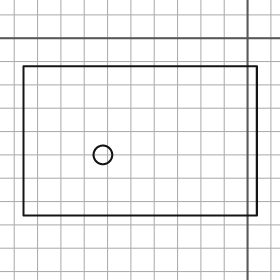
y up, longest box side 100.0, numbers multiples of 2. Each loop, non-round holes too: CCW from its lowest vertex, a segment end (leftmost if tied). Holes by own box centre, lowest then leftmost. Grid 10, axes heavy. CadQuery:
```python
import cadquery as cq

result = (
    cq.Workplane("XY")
    .moveTo(-96.0, -76.0)
    .lineTo(4.0, -76.0)
    .lineTo(4.0, -12.0)
    .lineTo(-96.0, -12.0)
    .close()
    .moveTo(-62.0, -50.0)
    .circle(4.0)
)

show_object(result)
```